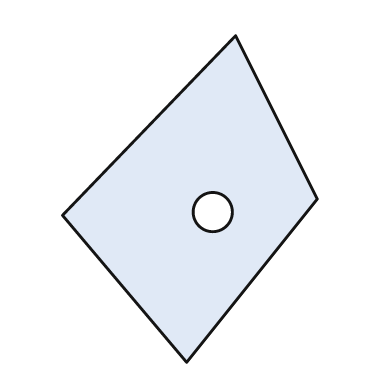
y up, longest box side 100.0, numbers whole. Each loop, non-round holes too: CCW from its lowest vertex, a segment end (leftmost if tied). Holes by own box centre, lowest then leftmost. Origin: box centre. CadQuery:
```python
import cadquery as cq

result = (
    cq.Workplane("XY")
    .moveTo(-1.0, -50.0)
    .lineTo(39.0, 0.0)
    .lineTo(14.0, 50.0)
    .lineTo(-39.0, -5.0)
    .close()
    .moveTo(7.0, -4.0)
    .circle(6.0)
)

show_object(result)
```